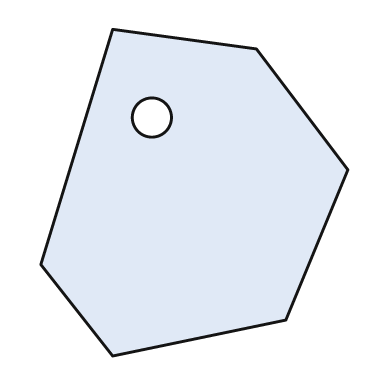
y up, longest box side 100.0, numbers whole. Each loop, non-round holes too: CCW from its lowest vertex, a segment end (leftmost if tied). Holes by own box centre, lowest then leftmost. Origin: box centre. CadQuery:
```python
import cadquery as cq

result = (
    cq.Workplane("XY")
    .moveTo(-25.0, -50.0)
    .lineTo(28.0, -39.0)
    .lineTo(47.0, 7.0)
    .lineTo(19.0, 44.0)
    .lineTo(-25.0, 50.0)
    .lineTo(-47.0, -22.0)
    .close()
    .moveTo(-13.0, 23.0)
    .circle(6.0)
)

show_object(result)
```